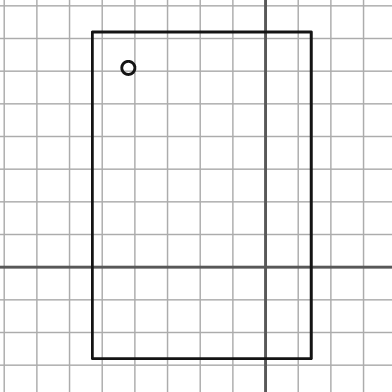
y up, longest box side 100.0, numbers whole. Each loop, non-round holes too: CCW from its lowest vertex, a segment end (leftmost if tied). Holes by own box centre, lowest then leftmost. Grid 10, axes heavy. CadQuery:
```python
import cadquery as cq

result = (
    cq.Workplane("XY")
    .moveTo(-53.0, -28.0)
    .lineTo(14.0, -28.0)
    .lineTo(14.0, 72.0)
    .lineTo(-53.0, 72.0)
    .close()
    .moveTo(-42.0, 61.0)
    .circle(2.0)
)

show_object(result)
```